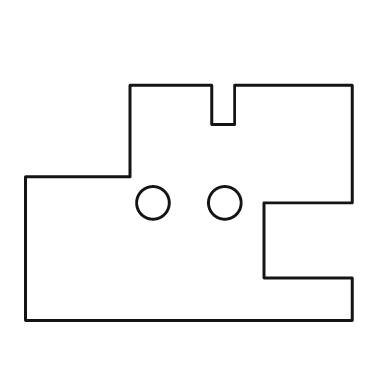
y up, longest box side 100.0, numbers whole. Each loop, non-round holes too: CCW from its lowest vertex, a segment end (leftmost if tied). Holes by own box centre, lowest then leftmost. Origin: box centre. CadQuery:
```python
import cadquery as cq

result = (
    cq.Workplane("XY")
    .moveTo(-50.0, -36.0)
    .lineTo(50.0, -36.0)
    .lineTo(50.0, -23.0)
    .lineTo(23.0, -23.0)
    .lineTo(23.0, 0.0)
    .lineTo(50.0, 0.0)
    .lineTo(50.0, 36.0)
    .lineTo(14.0, 36.0)
    .lineTo(14.0, 24.0)
    .lineTo(7.0, 24.0)
    .lineTo(7.0, 36.0)
    .lineTo(-18.0, 36.0)
    .lineTo(-18.0, 8.0)
    .lineTo(-50.0, 8.0)
    .close()
    .moveTo(-11.0, 0.0)
    .circle(5.0)
    .moveTo(11.0, 0.0)
    .circle(5.0)
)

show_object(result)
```